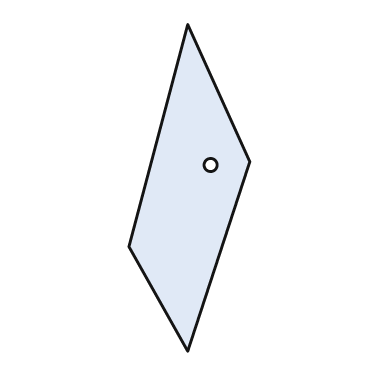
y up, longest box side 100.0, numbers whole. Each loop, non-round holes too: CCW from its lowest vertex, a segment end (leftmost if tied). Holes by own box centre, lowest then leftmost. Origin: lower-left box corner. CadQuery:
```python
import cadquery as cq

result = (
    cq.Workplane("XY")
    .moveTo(18.0, 0.0)
    .lineTo(37.0, 58.0)
    .lineTo(18.0, 100.0)
    .lineTo(0.0, 32.0)
    .close()
    .moveTo(25.0, 57.0)
    .circle(2.0)
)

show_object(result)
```